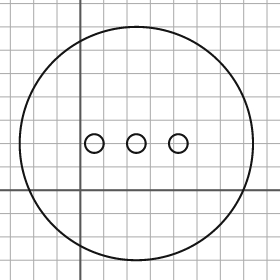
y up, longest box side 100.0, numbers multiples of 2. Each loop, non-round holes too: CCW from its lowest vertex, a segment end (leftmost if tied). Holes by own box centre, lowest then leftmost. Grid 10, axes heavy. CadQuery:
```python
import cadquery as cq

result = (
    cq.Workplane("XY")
    .moveTo(24.0, 20.0)
    .circle(50.0)
    .moveTo(6.0, 20.0)
    .circle(4.0)
    .moveTo(24.0, 20.0)
    .circle(4.0)
    .moveTo(42.0, 20.0)
    .circle(4.0)
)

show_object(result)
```